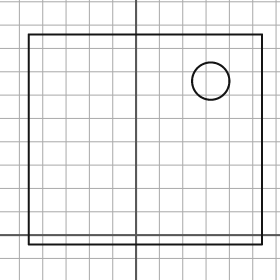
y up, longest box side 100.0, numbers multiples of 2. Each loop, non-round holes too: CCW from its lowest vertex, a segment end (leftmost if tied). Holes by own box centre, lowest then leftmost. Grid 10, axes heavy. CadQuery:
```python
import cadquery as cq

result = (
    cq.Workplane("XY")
    .moveTo(-46.0, -4.0)
    .lineTo(54.0, -4.0)
    .lineTo(54.0, 86.0)
    .lineTo(-46.0, 86.0)
    .close()
    .moveTo(32.0, 66.0)
    .circle(8.0)
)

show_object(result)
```